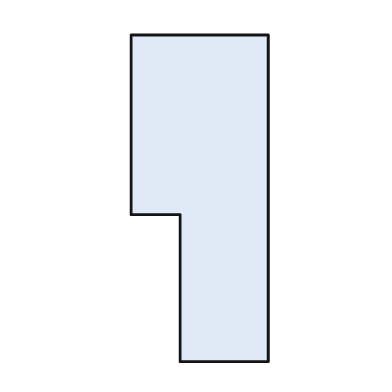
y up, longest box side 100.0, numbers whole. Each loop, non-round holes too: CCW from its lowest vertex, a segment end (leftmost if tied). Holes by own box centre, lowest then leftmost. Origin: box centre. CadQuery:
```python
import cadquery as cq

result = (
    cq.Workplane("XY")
    .moveTo(-6.0, -50.0)
    .lineTo(21.0, -50.0)
    .lineTo(21.0, 50.0)
    .lineTo(-21.0, 50.0)
    .lineTo(-21.0, -5.0)
    .lineTo(-6.0, -5.0)
    .close()
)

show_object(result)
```